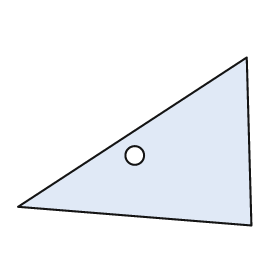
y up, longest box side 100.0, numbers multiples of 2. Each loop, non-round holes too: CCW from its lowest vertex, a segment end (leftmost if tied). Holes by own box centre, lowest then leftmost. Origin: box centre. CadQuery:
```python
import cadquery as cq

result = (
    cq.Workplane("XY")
    .moveTo(50.0, -36.0)
    .lineTo(48.0, 36.0)
    .lineTo(-50.0, -28.0)
    .close()
    .moveTo(0.0, -6.0)
    .circle(4.0)
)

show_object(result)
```